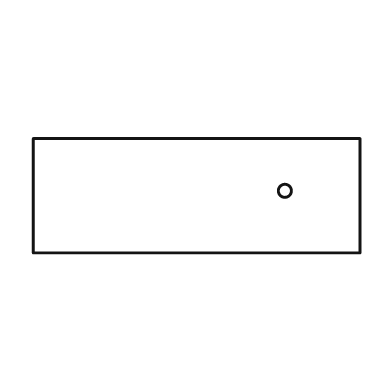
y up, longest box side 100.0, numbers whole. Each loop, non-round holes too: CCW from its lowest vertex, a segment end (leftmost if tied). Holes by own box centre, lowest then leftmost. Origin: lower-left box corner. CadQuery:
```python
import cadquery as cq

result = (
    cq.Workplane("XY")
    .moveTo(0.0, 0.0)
    .lineTo(100.0, 0.0)
    .lineTo(100.0, 35.0)
    .lineTo(0.0, 35.0)
    .close()
    .moveTo(77.0, 19.0)
    .circle(2.0)
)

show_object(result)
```